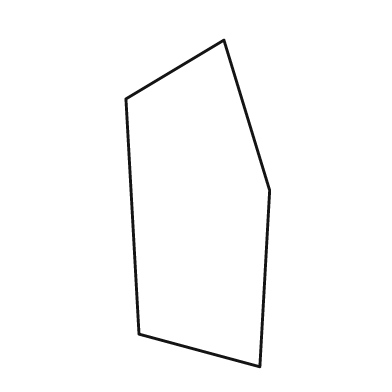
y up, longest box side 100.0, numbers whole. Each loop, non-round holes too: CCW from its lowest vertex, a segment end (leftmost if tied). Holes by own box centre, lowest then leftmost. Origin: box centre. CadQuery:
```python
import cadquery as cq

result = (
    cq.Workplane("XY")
    .moveTo(19.0, -50.0)
    .lineTo(22.0, 4.0)
    .lineTo(8.0, 50.0)
    .lineTo(-22.0, 32.0)
    .lineTo(-18.0, -40.0)
    .close()
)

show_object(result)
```